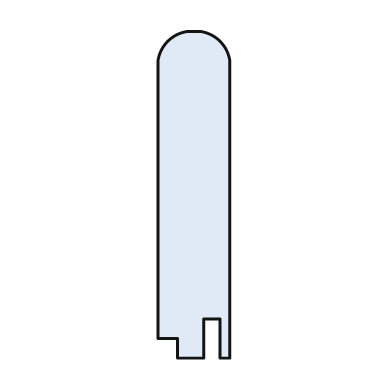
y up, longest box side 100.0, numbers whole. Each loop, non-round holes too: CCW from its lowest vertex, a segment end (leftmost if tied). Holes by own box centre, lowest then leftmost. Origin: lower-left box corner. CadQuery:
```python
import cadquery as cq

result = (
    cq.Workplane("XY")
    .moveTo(6.0, 0.0)
    .lineTo(14.0, 0.0)
    .lineTo(14.0, 12.0)
    .lineTo(19.0, 12.0)
    .lineTo(19.0, 0.0)
    .lineTo(22.0, 0.0)
    .lineTo(22.0, 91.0)
    .threePointArc((19.0, 97.0), (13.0, 100.0))
    .lineTo(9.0, 100.0)
    .threePointArc((3.0, 97.0), (0.0, 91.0))
    .lineTo(0.0, 6.0)
    .lineTo(6.0, 6.0)
    .close()
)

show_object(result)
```